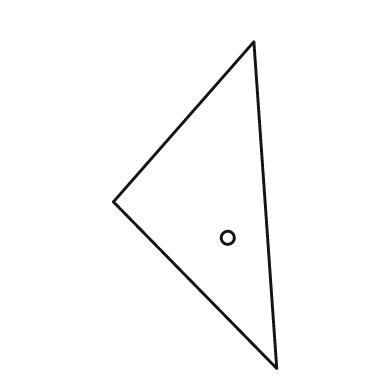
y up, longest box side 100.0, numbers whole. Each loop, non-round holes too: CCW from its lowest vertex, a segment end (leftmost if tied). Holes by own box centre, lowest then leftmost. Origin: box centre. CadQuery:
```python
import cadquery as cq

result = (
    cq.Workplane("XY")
    .moveTo(25.0, -50.0)
    .lineTo(18.0, 50.0)
    .lineTo(-25.0, 1.0)
    .close()
    .moveTo(10.0, -10.0)
    .circle(2.0)
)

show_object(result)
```